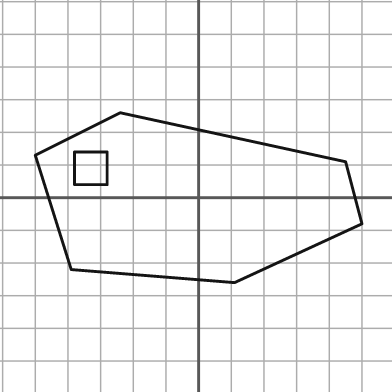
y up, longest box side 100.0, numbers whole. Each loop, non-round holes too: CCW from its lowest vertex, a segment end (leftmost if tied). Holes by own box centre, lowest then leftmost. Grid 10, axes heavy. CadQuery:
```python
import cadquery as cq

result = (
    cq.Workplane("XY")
    .moveTo(11.0, -26.0)
    .lineTo(50.0, -8.0)
    .lineTo(45.0, 11.0)
    .lineTo(-24.0, 26.0)
    .lineTo(-50.0, 13.0)
    .lineTo(-39.0, -22.0)
    .close()
    .moveTo(-38.0, 4.0)
    .lineTo(-28.0, 4.0)
    .lineTo(-28.0, 14.0)
    .lineTo(-38.0, 14.0)
    .close()
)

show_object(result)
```